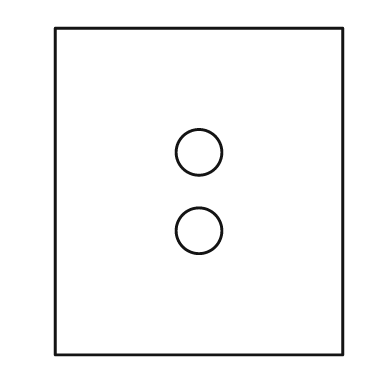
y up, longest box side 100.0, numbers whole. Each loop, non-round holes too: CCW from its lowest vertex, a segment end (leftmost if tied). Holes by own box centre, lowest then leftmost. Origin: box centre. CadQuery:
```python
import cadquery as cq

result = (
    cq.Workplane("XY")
    .moveTo(-44.0, -50.0)
    .lineTo(44.0, -50.0)
    .lineTo(44.0, 50.0)
    .lineTo(-44.0, 50.0)
    .close()
    .moveTo(0.0, -12.0)
    .circle(7.0)
    .moveTo(0.0, 12.0)
    .circle(7.0)
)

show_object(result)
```